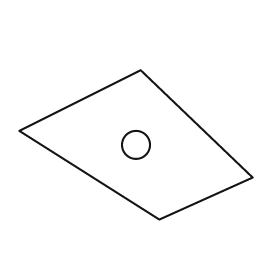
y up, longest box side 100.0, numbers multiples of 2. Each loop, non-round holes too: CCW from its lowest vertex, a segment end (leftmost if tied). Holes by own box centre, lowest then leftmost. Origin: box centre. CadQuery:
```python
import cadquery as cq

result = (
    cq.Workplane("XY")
    .moveTo(10.0, -32.0)
    .lineTo(50.0, -14.0)
    .lineTo(2.0, 32.0)
    .lineTo(-50.0, 6.0)
    .close()
    .moveTo(0.0, 0.0)
    .circle(6.0)
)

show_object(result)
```